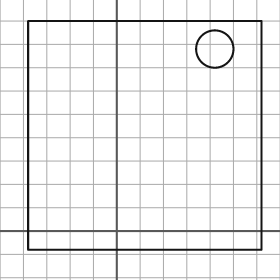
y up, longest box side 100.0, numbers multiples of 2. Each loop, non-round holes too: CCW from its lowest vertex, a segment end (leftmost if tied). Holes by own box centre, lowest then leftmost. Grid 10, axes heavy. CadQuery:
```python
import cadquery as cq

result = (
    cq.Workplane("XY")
    .moveTo(-38.0, -8.0)
    .lineTo(62.0, -8.0)
    .lineTo(62.0, 90.0)
    .lineTo(-38.0, 90.0)
    .close()
    .moveTo(42.0, 78.0)
    .circle(8.0)
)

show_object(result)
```